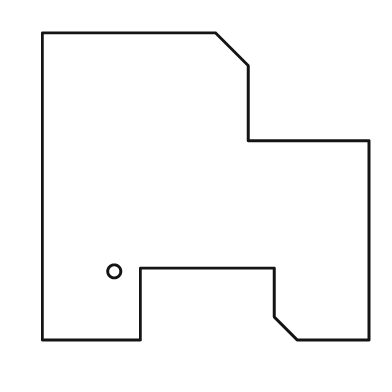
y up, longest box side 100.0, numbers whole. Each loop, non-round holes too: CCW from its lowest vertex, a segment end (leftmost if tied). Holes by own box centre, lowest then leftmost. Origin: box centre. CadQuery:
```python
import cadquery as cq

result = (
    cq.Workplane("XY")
    .moveTo(-50.0, -47.0)
    .lineTo(-20.0, -47.0)
    .lineTo(-20.0, -25.0)
    .lineTo(21.0, -25.0)
    .lineTo(21.0, -40.0)
    .lineTo(28.0, -47.0)
    .lineTo(50.0, -47.0)
    .lineTo(50.0, 14.0)
    .lineTo(13.0, 14.0)
    .lineTo(13.0, 37.0)
    .lineTo(3.0, 47.0)
    .lineTo(-50.0, 47.0)
    .close()
    .moveTo(-28.0, -26.0)
    .circle(2.0)
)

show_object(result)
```